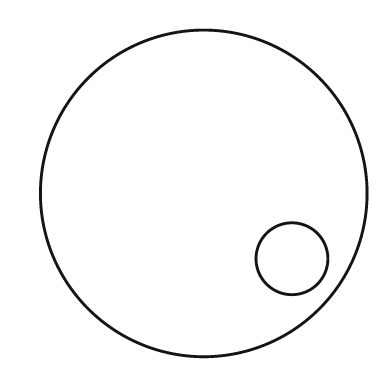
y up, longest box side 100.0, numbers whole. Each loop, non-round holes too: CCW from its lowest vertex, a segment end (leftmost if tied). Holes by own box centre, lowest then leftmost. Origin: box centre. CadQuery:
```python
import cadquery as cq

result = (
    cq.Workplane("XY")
    .moveTo(0.0, 0.0)
    .circle(50.0)
    .moveTo(27.0, -20.0)
    .circle(11.0)
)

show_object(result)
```